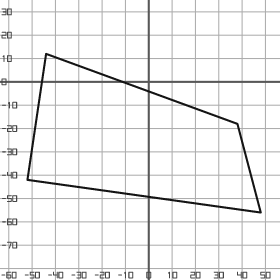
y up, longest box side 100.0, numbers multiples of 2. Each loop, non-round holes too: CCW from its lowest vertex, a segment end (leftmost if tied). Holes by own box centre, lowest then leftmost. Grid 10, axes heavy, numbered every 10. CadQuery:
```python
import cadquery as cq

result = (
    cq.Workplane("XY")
    .moveTo(48.0, -56.0)
    .lineTo(38.0, -18.0)
    .lineTo(-44.0, 12.0)
    .lineTo(-52.0, -42.0)
    .close()
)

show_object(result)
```